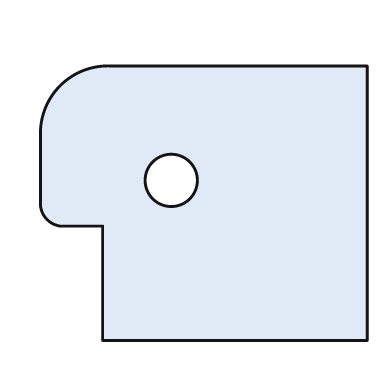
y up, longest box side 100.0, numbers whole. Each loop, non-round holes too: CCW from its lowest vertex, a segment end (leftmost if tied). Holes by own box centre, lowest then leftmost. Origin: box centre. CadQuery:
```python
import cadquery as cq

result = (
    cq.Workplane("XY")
    .moveTo(-31.0, -42.0)
    .lineTo(50.0, -42.0)
    .lineTo(50.0, 42.0)
    .lineTo(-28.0, 42.0)
    .threePointArc((-44.0, 36.0), (-50.0, 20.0))
    .lineTo(-50.0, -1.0)
    .threePointArc((-48.0, -5.0), (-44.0, -7.0))
    .lineTo(-31.0, -7.0)
    .close()
    .moveTo(-10.0, 7.0)
    .circle(8.0)
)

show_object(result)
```